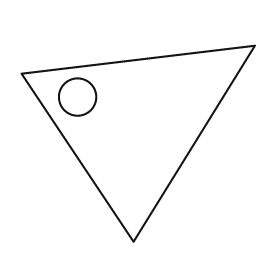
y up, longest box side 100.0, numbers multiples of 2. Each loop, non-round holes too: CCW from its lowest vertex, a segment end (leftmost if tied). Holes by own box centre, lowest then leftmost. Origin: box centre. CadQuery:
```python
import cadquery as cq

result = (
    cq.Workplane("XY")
    .moveTo(-2.0, -42.0)
    .lineTo(50.0, 42.0)
    .lineTo(-50.0, 30.0)
    .close()
    .moveTo(-26.0, 20.0)
    .circle(8.0)
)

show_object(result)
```